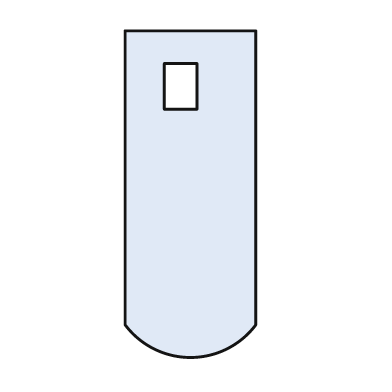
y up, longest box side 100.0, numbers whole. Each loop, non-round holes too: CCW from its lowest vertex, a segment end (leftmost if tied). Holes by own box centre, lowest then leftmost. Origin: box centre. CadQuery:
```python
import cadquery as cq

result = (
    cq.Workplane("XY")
    .moveTo(-20.0, -40.0)
    .threePointArc((0.0, -50.0), (20.0, -40.0))
    .lineTo(20.0, 50.0)
    .lineTo(-20.0, 50.0)
    .close()
    .moveTo(-8.0, 26.0)
    .lineTo(2.0, 26.0)
    .lineTo(2.0, 40.0)
    .lineTo(-8.0, 40.0)
    .close()
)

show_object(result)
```